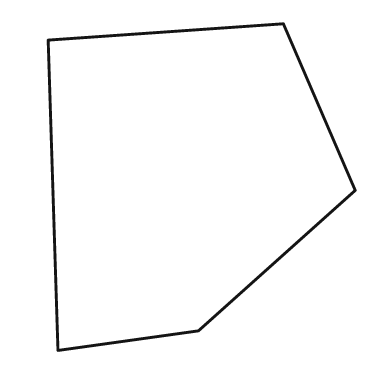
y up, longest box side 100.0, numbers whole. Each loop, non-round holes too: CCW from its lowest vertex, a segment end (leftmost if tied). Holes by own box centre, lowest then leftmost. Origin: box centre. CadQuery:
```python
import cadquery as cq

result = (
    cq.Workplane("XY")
    .moveTo(-44.0, -50.0)
    .lineTo(-1.0, -44.0)
    .lineTo(47.0, -1.0)
    .lineTo(25.0, 50.0)
    .lineTo(-47.0, 45.0)
    .close()
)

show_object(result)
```